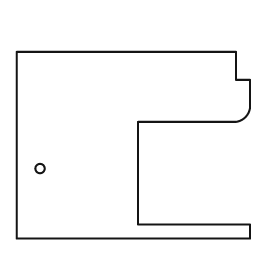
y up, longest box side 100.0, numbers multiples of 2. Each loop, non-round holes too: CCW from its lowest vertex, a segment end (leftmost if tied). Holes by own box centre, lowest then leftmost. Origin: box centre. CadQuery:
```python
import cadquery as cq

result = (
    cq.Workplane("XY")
    .moveTo(-50.0, -40.0)
    .lineTo(50.0, -40.0)
    .lineTo(50.0, -34.0)
    .lineTo(2.0, -34.0)
    .lineTo(2.0, 10.0)
    .lineTo(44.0, 10.0)
    .threePointArc((48.0, 12.0), (50.0, 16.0))
    .lineTo(50.0, 28.0)
    .lineTo(44.0, 28.0)
    .lineTo(44.0, 40.0)
    .lineTo(-50.0, 40.0)
    .close()
    .moveTo(-40.0, -10.0)
    .circle(2.0)
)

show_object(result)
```